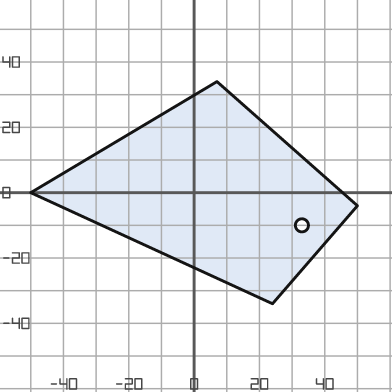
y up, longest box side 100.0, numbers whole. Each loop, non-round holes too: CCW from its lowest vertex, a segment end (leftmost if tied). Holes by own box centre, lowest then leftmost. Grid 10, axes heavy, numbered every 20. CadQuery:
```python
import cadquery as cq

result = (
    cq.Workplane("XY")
    .moveTo(24.0, -34.0)
    .lineTo(50.0, -4.0)
    .lineTo(7.0, 34.0)
    .lineTo(-50.0, 0.0)
    .close()
    .moveTo(33.0, -10.0)
    .circle(2.0)
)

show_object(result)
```